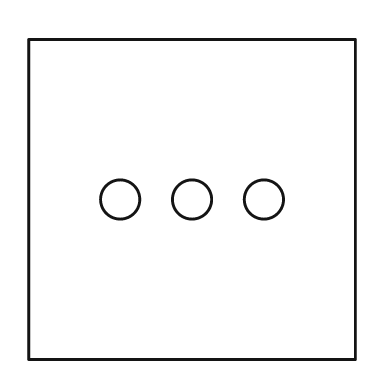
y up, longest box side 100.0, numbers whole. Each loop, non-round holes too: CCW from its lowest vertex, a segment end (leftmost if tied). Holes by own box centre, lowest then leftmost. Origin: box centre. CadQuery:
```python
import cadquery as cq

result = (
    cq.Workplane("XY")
    .moveTo(-50.0, -49.0)
    .lineTo(50.0, -49.0)
    .lineTo(50.0, 49.0)
    .lineTo(-50.0, 49.0)
    .close()
    .moveTo(-22.0, 0.0)
    .circle(6.0)
    .moveTo(0.0, 0.0)
    .circle(6.0)
    .moveTo(22.0, 0.0)
    .circle(6.0)
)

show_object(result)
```